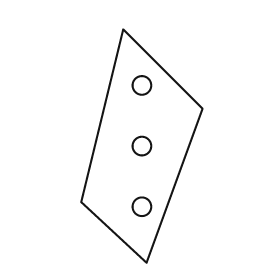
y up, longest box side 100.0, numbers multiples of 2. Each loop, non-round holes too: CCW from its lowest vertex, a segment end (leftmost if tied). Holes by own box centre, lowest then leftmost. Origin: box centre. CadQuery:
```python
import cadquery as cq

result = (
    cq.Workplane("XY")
    .moveTo(2.0, -50.0)
    .lineTo(26.0, 16.0)
    .lineTo(-8.0, 50.0)
    .lineTo(-26.0, -24.0)
    .close()
    .moveTo(0.0, -26.0)
    .circle(4.0)
    .moveTo(0.0, 0.0)
    .circle(4.0)
    .moveTo(0.0, 26.0)
    .circle(4.0)
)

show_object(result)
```